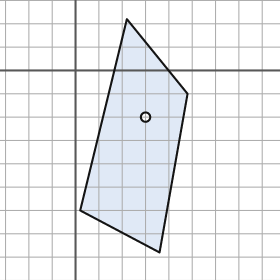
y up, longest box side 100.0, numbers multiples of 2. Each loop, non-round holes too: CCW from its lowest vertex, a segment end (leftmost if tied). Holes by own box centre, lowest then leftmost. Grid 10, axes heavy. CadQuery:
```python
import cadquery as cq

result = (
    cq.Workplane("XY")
    .moveTo(36.0, -78.0)
    .lineTo(48.0, -10.0)
    .lineTo(22.0, 22.0)
    .lineTo(2.0, -60.0)
    .close()
    .moveTo(30.0, -20.0)
    .circle(2.0)
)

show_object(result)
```